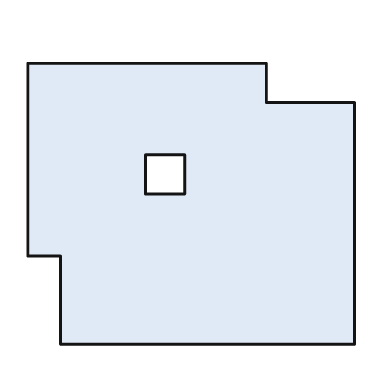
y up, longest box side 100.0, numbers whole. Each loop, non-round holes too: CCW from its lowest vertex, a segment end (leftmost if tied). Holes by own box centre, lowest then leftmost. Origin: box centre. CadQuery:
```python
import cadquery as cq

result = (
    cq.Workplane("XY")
    .moveTo(-40.0, -43.0)
    .lineTo(50.0, -43.0)
    .lineTo(50.0, 31.0)
    .lineTo(23.0, 31.0)
    .lineTo(23.0, 43.0)
    .lineTo(-50.0, 43.0)
    .lineTo(-50.0, -16.0)
    .lineTo(-40.0, -16.0)
    .close()
    .moveTo(-14.0, 3.0)
    .lineTo(-2.0, 3.0)
    .lineTo(-2.0, 15.0)
    .lineTo(-14.0, 15.0)
    .close()
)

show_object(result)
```